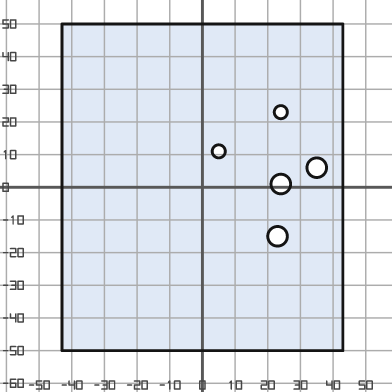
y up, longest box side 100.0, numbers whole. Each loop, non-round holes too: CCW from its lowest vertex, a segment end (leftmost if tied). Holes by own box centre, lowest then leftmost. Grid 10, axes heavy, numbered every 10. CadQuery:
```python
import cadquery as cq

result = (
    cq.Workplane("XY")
    .moveTo(-43.0, -50.0)
    .lineTo(43.0, -50.0)
    .lineTo(43.0, 50.0)
    .lineTo(-43.0, 50.0)
    .close()
    .moveTo(23.0, -15.0)
    .circle(3.0)
    .moveTo(24.0, 1.0)
    .circle(3.0)
    .moveTo(35.0, 6.0)
    .circle(3.0)
    .moveTo(5.0, 11.0)
    .circle(2.0)
    .moveTo(24.0, 23.0)
    .circle(2.0)
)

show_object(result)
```